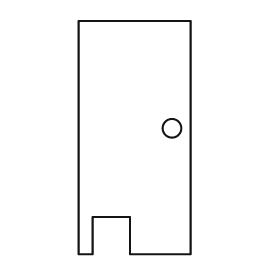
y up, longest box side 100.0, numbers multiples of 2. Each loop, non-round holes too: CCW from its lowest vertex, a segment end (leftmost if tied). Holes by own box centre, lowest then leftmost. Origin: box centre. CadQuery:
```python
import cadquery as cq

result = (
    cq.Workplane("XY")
    .moveTo(-24.0, -50.0)
    .lineTo(-18.0, -50.0)
    .lineTo(-18.0, -34.0)
    .lineTo(-2.0, -34.0)
    .lineTo(-2.0, -50.0)
    .lineTo(24.0, -50.0)
    .lineTo(24.0, 50.0)
    .lineTo(-24.0, 50.0)
    .close()
    .moveTo(16.0, 4.0)
    .circle(4.0)
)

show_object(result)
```